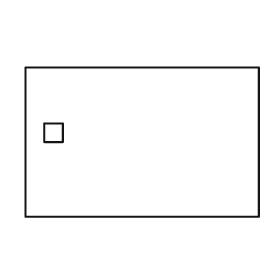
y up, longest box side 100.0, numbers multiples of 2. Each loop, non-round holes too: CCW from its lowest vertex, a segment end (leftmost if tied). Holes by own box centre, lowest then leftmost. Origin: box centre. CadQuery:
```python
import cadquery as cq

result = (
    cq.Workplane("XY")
    .moveTo(-50.0, -32.0)
    .lineTo(50.0, -32.0)
    .lineTo(50.0, 32.0)
    .lineTo(-50.0, 32.0)
    .close()
    .moveTo(-42.0, 0.0)
    .lineTo(-34.0, 0.0)
    .lineTo(-34.0, 8.0)
    .lineTo(-42.0, 8.0)
    .close()
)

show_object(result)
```